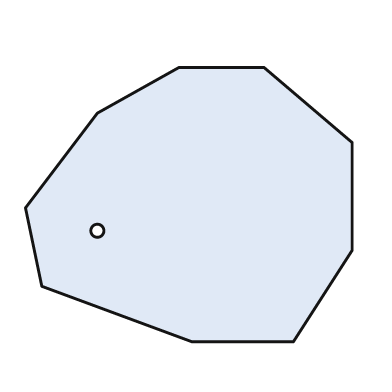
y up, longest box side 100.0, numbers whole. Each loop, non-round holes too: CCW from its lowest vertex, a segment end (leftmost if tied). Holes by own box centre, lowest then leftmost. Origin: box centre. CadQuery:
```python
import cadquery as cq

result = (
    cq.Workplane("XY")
    .moveTo(1.0, -42.0)
    .lineTo(32.0, -42.0)
    .lineTo(50.0, -14.0)
    .lineTo(50.0, 19.0)
    .lineTo(23.0, 42.0)
    .lineTo(-3.0, 42.0)
    .lineTo(-28.0, 28.0)
    .lineTo(-50.0, -1.0)
    .lineTo(-45.0, -25.0)
    .close()
    .moveTo(-28.0, -8.0)
    .circle(2.0)
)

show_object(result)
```